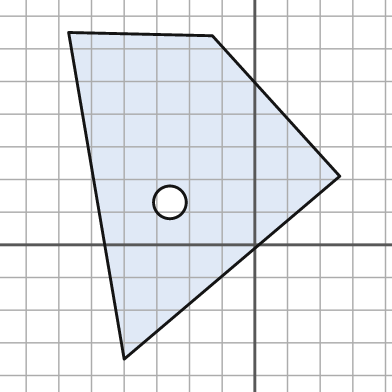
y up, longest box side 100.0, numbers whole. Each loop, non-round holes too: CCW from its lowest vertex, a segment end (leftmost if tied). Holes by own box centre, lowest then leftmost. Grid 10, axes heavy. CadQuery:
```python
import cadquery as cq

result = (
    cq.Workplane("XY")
    .moveTo(-40.0, -35.0)
    .lineTo(26.0, 21.0)
    .lineTo(-13.0, 64.0)
    .lineTo(-57.0, 65.0)
    .close()
    .moveTo(-26.0, 13.0)
    .circle(5.0)
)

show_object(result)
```